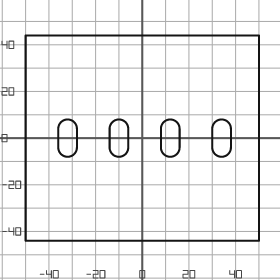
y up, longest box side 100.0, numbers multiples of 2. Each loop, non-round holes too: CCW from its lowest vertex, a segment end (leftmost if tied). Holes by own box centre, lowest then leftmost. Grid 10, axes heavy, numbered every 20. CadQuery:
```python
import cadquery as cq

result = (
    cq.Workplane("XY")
    .moveTo(-50.0, -44.0)
    .lineTo(50.0, -44.0)
    .lineTo(50.0, 44.0)
    .lineTo(-50.0, 44.0)
    .close()
    .moveTo(-36.0, -4.0)
    .threePointArc((-32.0, -8.0), (-28.0, -4.0))
    .lineTo(-28.0, 4.0)
    .threePointArc((-32.0, 8.0), (-36.0, 4.0))
    .close()
    .moveTo(-14.0, -4.0)
    .threePointArc((-10.0, -8.0), (-6.0, -4.0))
    .lineTo(-6.0, 4.0)
    .threePointArc((-10.0, 8.0), (-14.0, 4.0))
    .close()
    .moveTo(8.0, -4.0)
    .threePointArc((12.0, -8.0), (16.0, -4.0))
    .lineTo(16.0, 4.0)
    .threePointArc((12.0, 8.0), (8.0, 4.0))
    .close()
    .moveTo(30.0, -4.0)
    .threePointArc((34.0, -8.0), (38.0, -4.0))
    .lineTo(38.0, 4.0)
    .threePointArc((34.0, 8.0), (30.0, 4.0))
    .close()
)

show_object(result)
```